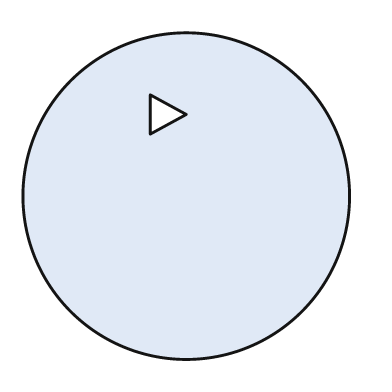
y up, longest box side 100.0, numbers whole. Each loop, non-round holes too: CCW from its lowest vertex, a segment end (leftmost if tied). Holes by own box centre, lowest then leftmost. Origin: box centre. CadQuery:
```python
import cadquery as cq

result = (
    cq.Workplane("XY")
    .moveTo(0.0, 0.0)
    .circle(50.0)
    .moveTo(-11.0, 19.0)
    .lineTo(0.0, 25.0)
    .lineTo(-11.0, 31.0)
    .close()
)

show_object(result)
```